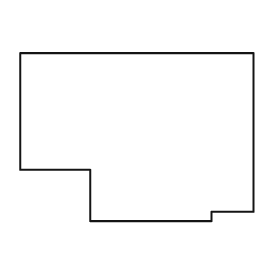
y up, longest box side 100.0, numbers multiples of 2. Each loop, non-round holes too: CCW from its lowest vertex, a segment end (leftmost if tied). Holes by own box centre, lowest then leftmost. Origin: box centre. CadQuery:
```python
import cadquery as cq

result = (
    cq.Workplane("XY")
    .moveTo(-20.0, -36.0)
    .lineTo(32.0, -36.0)
    .lineTo(32.0, -32.0)
    .lineTo(50.0, -32.0)
    .lineTo(50.0, 36.0)
    .lineTo(-50.0, 36.0)
    .lineTo(-50.0, -14.0)
    .lineTo(-20.0, -14.0)
    .close()
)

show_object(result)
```